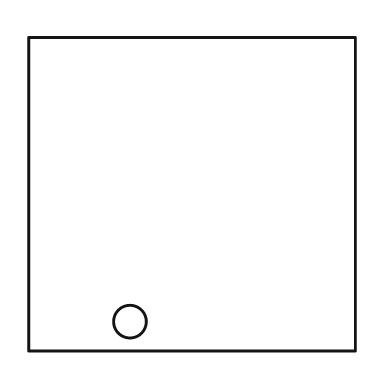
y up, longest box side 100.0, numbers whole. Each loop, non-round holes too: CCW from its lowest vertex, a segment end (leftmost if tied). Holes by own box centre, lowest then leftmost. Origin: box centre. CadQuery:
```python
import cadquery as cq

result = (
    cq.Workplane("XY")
    .moveTo(-50.0, -48.0)
    .lineTo(50.0, -48.0)
    .lineTo(50.0, 48.0)
    .lineTo(-50.0, 48.0)
    .close()
    .moveTo(-19.0, -39.0)
    .circle(5.0)
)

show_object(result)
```